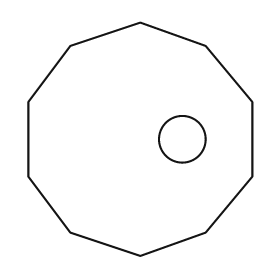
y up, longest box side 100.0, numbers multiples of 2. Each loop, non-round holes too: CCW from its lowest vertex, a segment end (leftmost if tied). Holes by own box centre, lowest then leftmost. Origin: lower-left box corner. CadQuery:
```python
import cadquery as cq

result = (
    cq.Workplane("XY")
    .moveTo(48.0, 0.0)
    .lineTo(76.0, 10.0)
    .lineTo(96.0, 34.0)
    .lineTo(96.0, 66.0)
    .lineTo(76.0, 90.0)
    .lineTo(48.0, 100.0)
    .lineTo(18.0, 90.0)
    .lineTo(0.0, 66.0)
    .lineTo(0.0, 34.0)
    .lineTo(18.0, 10.0)
    .close()
    .moveTo(66.0, 50.0)
    .circle(10.0)
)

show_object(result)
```